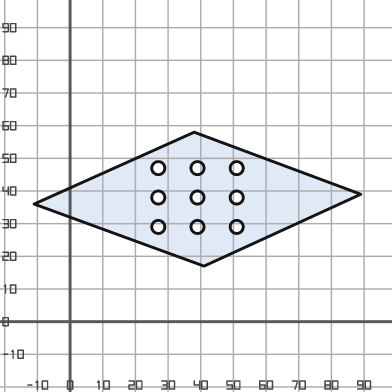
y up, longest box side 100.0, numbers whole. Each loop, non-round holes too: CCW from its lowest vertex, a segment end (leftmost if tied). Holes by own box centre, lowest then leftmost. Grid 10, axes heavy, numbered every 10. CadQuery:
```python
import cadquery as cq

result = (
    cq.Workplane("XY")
    .moveTo(41.0, 17.0)
    .lineTo(89.0, 39.0)
    .lineTo(38.0, 58.0)
    .lineTo(-11.0, 36.0)
    .close()
    .moveTo(27.0, 29.0)
    .circle(2.0)
    .moveTo(39.0, 29.0)
    .circle(2.0)
    .moveTo(51.0, 29.0)
    .circle(2.0)
    .moveTo(27.0, 38.0)
    .circle(2.0)
    .moveTo(39.0, 38.0)
    .circle(2.0)
    .moveTo(51.0, 38.0)
    .circle(2.0)
    .moveTo(27.0, 47.0)
    .circle(2.0)
    .moveTo(39.0, 47.0)
    .circle(2.0)
    .moveTo(51.0, 47.0)
    .circle(2.0)
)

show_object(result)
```